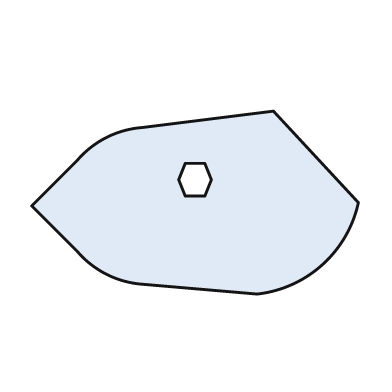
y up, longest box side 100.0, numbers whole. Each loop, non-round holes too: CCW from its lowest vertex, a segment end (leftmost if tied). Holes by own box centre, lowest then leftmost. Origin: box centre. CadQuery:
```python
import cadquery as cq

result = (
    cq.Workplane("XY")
    .moveTo(19.0, -28.0)
    .threePointArc((39.0, -19.0), (50.0, 0.0))
    .lineTo(24.0, 28.0)
    .lineTo(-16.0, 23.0)
    .threePointArc((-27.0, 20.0), (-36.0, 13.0))
    .lineTo(-50.0, -1.0)
    .lineTo(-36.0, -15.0)
    .threePointArc((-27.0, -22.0), (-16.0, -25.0))
    .close()
    .moveTo(-3.0, 2.0)
    .lineTo(3.0, 2.0)
    .lineTo(5.0, 7.0)
    .lineTo(3.0, 12.0)
    .lineTo(-3.0, 12.0)
    .lineTo(-5.0, 7.0)
    .close()
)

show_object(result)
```